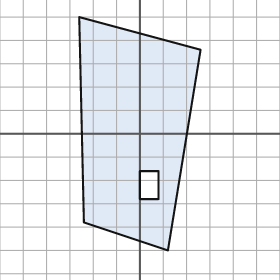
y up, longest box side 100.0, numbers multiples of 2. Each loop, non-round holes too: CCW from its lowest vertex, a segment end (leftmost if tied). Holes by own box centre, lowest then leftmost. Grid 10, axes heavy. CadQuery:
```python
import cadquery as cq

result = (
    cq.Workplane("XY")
    .moveTo(12.0, -50.0)
    .lineTo(26.0, 36.0)
    .lineTo(-26.0, 50.0)
    .lineTo(-24.0, -38.0)
    .close()
    .moveTo(0.0, -28.0)
    .lineTo(8.0, -28.0)
    .lineTo(8.0, -16.0)
    .lineTo(0.0, -16.0)
    .close()
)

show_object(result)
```